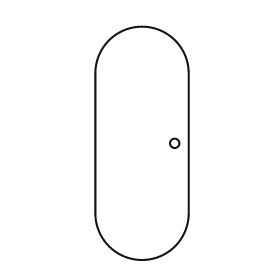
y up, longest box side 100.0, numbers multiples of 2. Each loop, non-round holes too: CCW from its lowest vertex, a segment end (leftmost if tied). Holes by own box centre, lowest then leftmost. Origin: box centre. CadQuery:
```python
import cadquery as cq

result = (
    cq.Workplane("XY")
    .moveTo(-20.0, -30.0)
    .threePointArc((0.0, -50.0), (20.0, -30.0))
    .lineTo(20.0, 30.0)
    .threePointArc((0.0, 50.0), (-20.0, 30.0))
    .close()
    .moveTo(14.0, 0.0)
    .circle(2.0)
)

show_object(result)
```